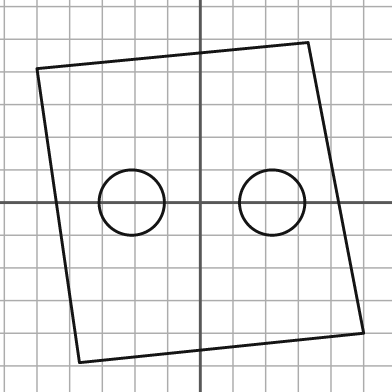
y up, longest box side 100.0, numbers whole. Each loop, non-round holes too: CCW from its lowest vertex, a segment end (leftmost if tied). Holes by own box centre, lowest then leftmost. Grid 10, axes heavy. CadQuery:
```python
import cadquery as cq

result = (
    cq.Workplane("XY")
    .moveTo(-37.0, -49.0)
    .lineTo(50.0, -40.0)
    .lineTo(33.0, 49.0)
    .lineTo(-50.0, 41.0)
    .close()
    .moveTo(-21.0, 0.0)
    .circle(10.0)
    .moveTo(22.0, 0.0)
    .circle(10.0)
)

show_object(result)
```